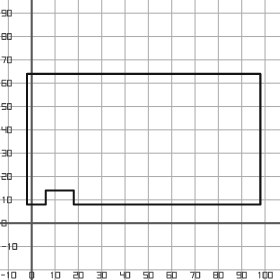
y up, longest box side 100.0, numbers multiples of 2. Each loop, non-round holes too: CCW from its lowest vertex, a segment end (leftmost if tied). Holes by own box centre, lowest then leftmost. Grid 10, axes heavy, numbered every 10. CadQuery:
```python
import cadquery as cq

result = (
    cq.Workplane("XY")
    .moveTo(-2.0, 8.0)
    .lineTo(6.0, 8.0)
    .lineTo(6.0, 14.0)
    .lineTo(18.0, 14.0)
    .lineTo(18.0, 8.0)
    .lineTo(98.0, 8.0)
    .lineTo(98.0, 64.0)
    .lineTo(-2.0, 64.0)
    .close()
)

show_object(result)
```